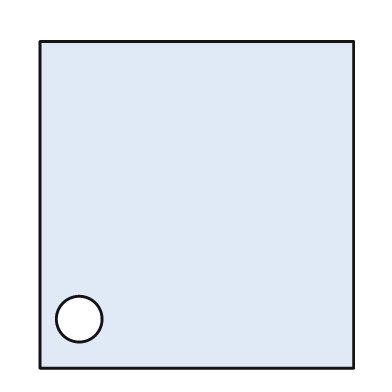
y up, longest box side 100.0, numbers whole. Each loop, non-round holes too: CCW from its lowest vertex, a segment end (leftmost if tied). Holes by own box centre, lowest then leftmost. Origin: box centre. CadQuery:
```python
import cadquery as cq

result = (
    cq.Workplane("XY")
    .moveTo(-48.0, -50.0)
    .lineTo(48.0, -50.0)
    .lineTo(48.0, 50.0)
    .lineTo(-48.0, 50.0)
    .close()
    .moveTo(-36.0, -35.0)
    .circle(7.0)
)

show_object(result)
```